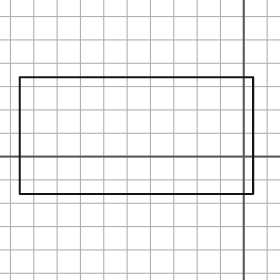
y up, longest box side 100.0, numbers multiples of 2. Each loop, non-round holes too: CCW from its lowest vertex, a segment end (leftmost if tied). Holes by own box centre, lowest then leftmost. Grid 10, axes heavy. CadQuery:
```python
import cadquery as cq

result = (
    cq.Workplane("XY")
    .moveTo(-96.0, -16.0)
    .lineTo(4.0, -16.0)
    .lineTo(4.0, 34.0)
    .lineTo(-96.0, 34.0)
    .close()
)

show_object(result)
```